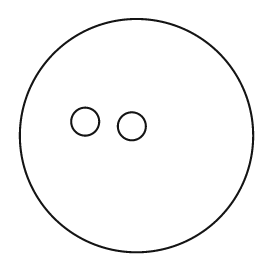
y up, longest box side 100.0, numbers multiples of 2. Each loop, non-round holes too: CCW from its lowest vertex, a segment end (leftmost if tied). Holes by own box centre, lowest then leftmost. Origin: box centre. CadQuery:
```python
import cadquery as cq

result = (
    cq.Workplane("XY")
    .moveTo(0.0, 0.0)
    .circle(50.0)
    .moveTo(-2.0, 4.0)
    .circle(6.0)
    .moveTo(-22.0, 6.0)
    .circle(6.0)
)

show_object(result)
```